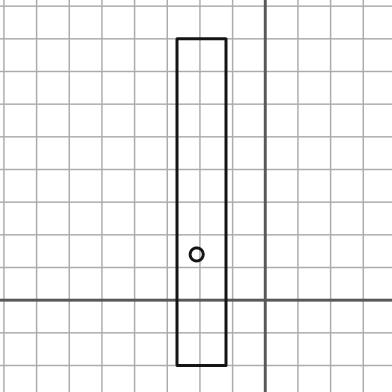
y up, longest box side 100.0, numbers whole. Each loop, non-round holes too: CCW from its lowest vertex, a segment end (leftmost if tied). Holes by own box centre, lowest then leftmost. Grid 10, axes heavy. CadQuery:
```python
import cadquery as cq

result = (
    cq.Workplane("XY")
    .moveTo(-27.0, -20.0)
    .lineTo(-12.0, -20.0)
    .lineTo(-12.0, 80.0)
    .lineTo(-27.0, 80.0)
    .close()
    .moveTo(-21.0, 14.0)
    .circle(2.0)
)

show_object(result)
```